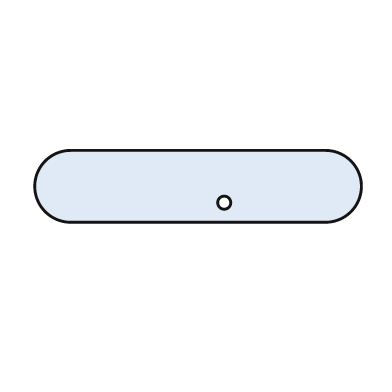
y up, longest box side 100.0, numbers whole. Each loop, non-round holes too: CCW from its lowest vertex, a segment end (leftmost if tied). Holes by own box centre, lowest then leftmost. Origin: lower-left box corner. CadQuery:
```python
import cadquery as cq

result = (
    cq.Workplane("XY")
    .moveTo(11.0, 0.0)
    .lineTo(89.0, 0.0)
    .threePointArc((100.0, 11.0), (89.0, 22.0))
    .lineTo(11.0, 22.0)
    .threePointArc((0.0, 11.0), (11.0, 0.0))
    .close()
    .moveTo(58.0, 6.0)
    .circle(2.0)
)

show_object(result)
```